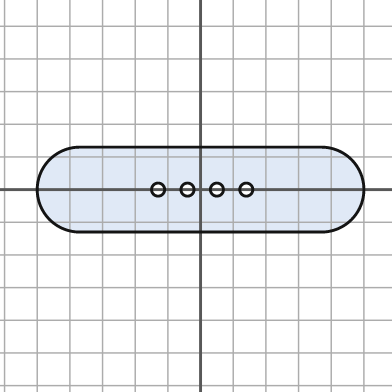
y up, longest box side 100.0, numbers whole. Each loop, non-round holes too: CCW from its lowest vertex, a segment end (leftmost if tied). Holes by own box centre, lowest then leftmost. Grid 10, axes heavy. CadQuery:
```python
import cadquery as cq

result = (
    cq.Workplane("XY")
    .moveTo(-37.0, -13.0)
    .lineTo(37.0, -13.0)
    .threePointArc((50.0, 0.0), (37.0, 13.0))
    .lineTo(-37.0, 13.0)
    .threePointArc((-50.0, 0.0), (-37.0, -13.0))
    .close()
    .moveTo(-13.0, 0.0)
    .circle(2.0)
    .moveTo(-4.0, 0.0)
    .circle(2.0)
    .moveTo(5.0, 0.0)
    .circle(2.0)
    .moveTo(14.0, 0.0)
    .circle(2.0)
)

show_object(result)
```